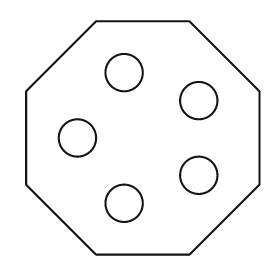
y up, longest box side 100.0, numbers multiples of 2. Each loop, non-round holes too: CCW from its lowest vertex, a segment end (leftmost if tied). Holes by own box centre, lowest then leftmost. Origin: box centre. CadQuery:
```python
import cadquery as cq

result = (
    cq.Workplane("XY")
    .moveTo(-20.0, -50.0)
    .lineTo(20.0, -50.0)
    .lineTo(50.0, -20.0)
    .lineTo(50.0, 20.0)
    .lineTo(20.0, 50.0)
    .lineTo(-20.0, 50.0)
    .lineTo(-50.0, 20.0)
    .lineTo(-50.0, -20.0)
    .close()
    .moveTo(-8.0, -28.0)
    .circle(8.0)
    .moveTo(24.0, -16.0)
    .circle(8.0)
    .moveTo(-28.0, 0.0)
    .circle(8.0)
    .moveTo(24.0, 16.0)
    .circle(8.0)
    .moveTo(-8.0, 28.0)
    .circle(8.0)
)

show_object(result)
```